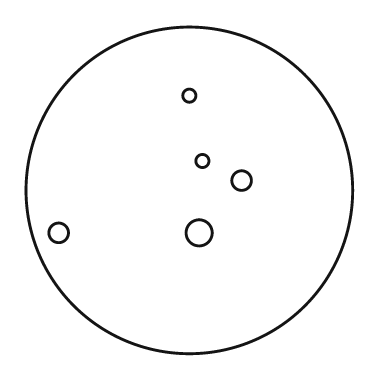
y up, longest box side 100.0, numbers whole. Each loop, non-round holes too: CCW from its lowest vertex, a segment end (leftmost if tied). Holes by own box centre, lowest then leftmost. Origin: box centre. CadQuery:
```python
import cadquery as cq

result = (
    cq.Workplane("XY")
    .moveTo(0.0, 0.0)
    .circle(50.0)
    .moveTo(-40.0, -13.0)
    .circle(3.0)
    .moveTo(3.0, -13.0)
    .circle(4.0)
    .moveTo(16.0, 3.0)
    .circle(3.0)
    .moveTo(4.0, 9.0)
    .circle(2.0)
    .moveTo(0.0, 29.0)
    .circle(2.0)
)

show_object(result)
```